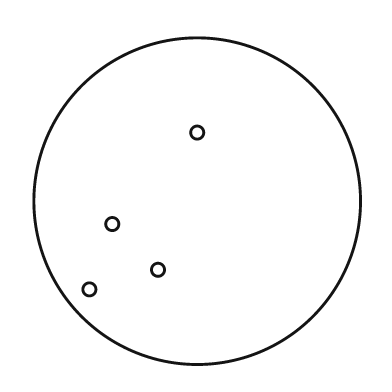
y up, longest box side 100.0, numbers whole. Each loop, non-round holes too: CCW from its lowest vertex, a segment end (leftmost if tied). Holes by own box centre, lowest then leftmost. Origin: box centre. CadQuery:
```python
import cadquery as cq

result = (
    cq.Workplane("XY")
    .moveTo(0.0, 0.0)
    .circle(50.0)
    .moveTo(-33.0, -27.0)
    .circle(2.0)
    .moveTo(-12.0, -21.0)
    .circle(2.0)
    .moveTo(-26.0, -7.0)
    .circle(2.0)
    .moveTo(0.0, 21.0)
    .circle(2.0)
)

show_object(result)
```